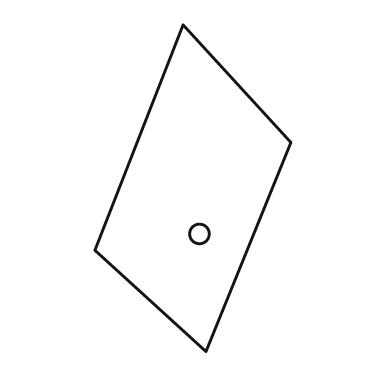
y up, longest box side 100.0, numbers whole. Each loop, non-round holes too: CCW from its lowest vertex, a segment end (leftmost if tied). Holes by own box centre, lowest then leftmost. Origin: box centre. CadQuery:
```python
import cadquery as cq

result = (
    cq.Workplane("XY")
    .moveTo(4.0, -50.0)
    .lineTo(30.0, 14.0)
    .lineTo(-3.0, 50.0)
    .lineTo(-30.0, -19.0)
    .close()
    .moveTo(2.0, -14.0)
    .circle(3.0)
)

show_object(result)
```